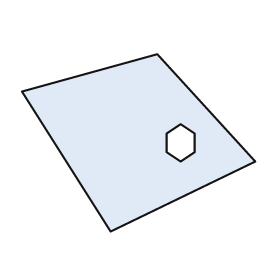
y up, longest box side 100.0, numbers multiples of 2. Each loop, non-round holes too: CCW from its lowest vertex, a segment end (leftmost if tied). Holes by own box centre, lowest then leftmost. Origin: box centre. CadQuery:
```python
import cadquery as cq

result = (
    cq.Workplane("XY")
    .moveTo(-12.0, -38.0)
    .lineTo(50.0, -8.0)
    .lineTo(8.0, 38.0)
    .lineTo(-50.0, 22.0)
    .close()
    .moveTo(18.0, -8.0)
    .lineTo(24.0, -4.0)
    .lineTo(24.0, 4.0)
    .lineTo(18.0, 8.0)
    .lineTo(12.0, 4.0)
    .lineTo(12.0, -4.0)
    .close()
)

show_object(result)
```